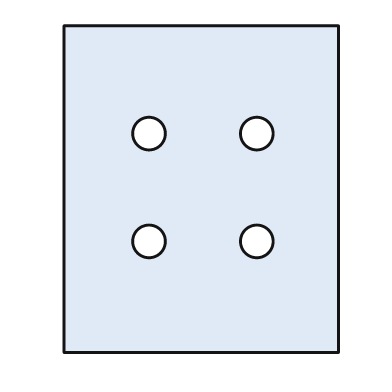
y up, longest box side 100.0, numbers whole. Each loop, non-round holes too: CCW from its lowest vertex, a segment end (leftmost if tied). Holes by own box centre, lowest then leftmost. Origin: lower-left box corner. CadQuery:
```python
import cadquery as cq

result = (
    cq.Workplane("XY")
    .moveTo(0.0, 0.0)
    .lineTo(84.0, 0.0)
    .lineTo(84.0, 100.0)
    .lineTo(0.0, 100.0)
    .close()
    .moveTo(26.0, 34.0)
    .circle(5.0)
    .moveTo(59.0, 34.0)
    .circle(5.0)
    .moveTo(26.0, 67.0)
    .circle(5.0)
    .moveTo(59.0, 67.0)
    .circle(5.0)
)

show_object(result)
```